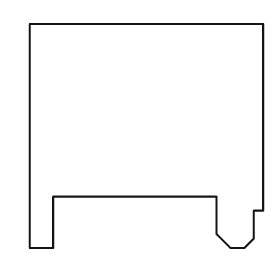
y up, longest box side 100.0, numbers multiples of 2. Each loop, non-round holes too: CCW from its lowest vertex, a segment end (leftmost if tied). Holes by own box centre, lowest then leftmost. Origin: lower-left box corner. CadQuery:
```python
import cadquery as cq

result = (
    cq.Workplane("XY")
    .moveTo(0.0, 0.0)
    .lineTo(10.0, 0.0)
    .lineTo(10.0, 22.0)
    .lineTo(80.0, 22.0)
    .lineTo(80.0, 6.0)
    .lineTo(86.0, 0.0)
    .lineTo(92.0, 0.0)
    .lineTo(96.0, 4.0)
    .lineTo(96.0, 16.0)
    .lineTo(100.0, 16.0)
    .lineTo(100.0, 96.0)
    .lineTo(0.0, 96.0)
    .close()
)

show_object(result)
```